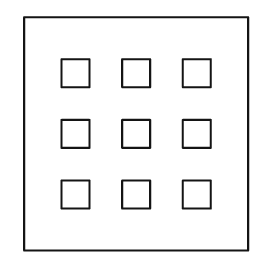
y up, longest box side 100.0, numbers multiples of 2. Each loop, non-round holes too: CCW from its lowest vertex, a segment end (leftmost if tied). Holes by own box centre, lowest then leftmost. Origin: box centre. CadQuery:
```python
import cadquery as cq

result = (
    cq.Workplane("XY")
    .moveTo(-48.0, -50.0)
    .lineTo(48.0, -50.0)
    .lineTo(48.0, 50.0)
    .lineTo(-48.0, 50.0)
    .close()
    .moveTo(-32.0, -32.0)
    .lineTo(-20.0, -32.0)
    .lineTo(-20.0, -20.0)
    .lineTo(-32.0, -20.0)
    .close()
    .moveTo(-6.0, -32.0)
    .lineTo(6.0, -32.0)
    .lineTo(6.0, -20.0)
    .lineTo(-6.0, -20.0)
    .close()
    .moveTo(20.0, -32.0)
    .lineTo(32.0, -32.0)
    .lineTo(32.0, -20.0)
    .lineTo(20.0, -20.0)
    .close()
    .moveTo(-32.0, -6.0)
    .lineTo(-20.0, -6.0)
    .lineTo(-20.0, 6.0)
    .lineTo(-32.0, 6.0)
    .close()
    .moveTo(-6.0, -6.0)
    .lineTo(6.0, -6.0)
    .lineTo(6.0, 6.0)
    .lineTo(-6.0, 6.0)
    .close()
    .moveTo(20.0, -6.0)
    .lineTo(32.0, -6.0)
    .lineTo(32.0, 6.0)
    .lineTo(20.0, 6.0)
    .close()
    .moveTo(-32.0, 20.0)
    .lineTo(-20.0, 20.0)
    .lineTo(-20.0, 32.0)
    .lineTo(-32.0, 32.0)
    .close()
    .moveTo(-6.0, 20.0)
    .lineTo(6.0, 20.0)
    .lineTo(6.0, 32.0)
    .lineTo(-6.0, 32.0)
    .close()
    .moveTo(20.0, 20.0)
    .lineTo(32.0, 20.0)
    .lineTo(32.0, 32.0)
    .lineTo(20.0, 32.0)
    .close()
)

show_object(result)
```